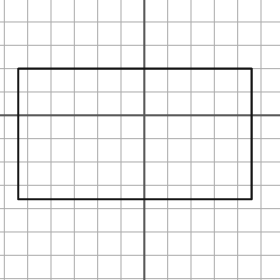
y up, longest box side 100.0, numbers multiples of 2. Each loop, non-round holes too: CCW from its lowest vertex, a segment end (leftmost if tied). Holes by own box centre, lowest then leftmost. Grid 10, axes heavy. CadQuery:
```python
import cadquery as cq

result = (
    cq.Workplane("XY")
    .moveTo(-54.0, -36.0)
    .lineTo(46.0, -36.0)
    .lineTo(46.0, 20.0)
    .lineTo(-54.0, 20.0)
    .close()
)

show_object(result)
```